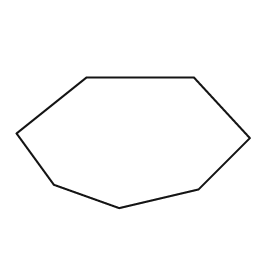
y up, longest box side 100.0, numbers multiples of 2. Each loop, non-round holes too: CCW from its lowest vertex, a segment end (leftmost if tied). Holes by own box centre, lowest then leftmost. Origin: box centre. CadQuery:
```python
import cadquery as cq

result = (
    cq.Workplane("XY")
    .moveTo(-6.0, -28.0)
    .lineTo(28.0, -20.0)
    .lineTo(50.0, 2.0)
    .lineTo(26.0, 28.0)
    .lineTo(-20.0, 28.0)
    .lineTo(-50.0, 4.0)
    .lineTo(-34.0, -18.0)
    .close()
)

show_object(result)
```